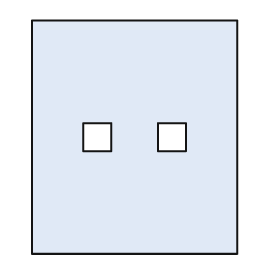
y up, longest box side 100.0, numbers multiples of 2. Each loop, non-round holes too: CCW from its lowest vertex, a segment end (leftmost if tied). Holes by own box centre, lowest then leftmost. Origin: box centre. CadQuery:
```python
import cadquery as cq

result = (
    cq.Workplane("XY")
    .moveTo(-44.0, -50.0)
    .lineTo(44.0, -50.0)
    .lineTo(44.0, 50.0)
    .lineTo(-44.0, 50.0)
    .close()
    .moveTo(-22.0, -6.0)
    .lineTo(-10.0, -6.0)
    .lineTo(-10.0, 6.0)
    .lineTo(-22.0, 6.0)
    .close()
    .moveTo(10.0, -6.0)
    .lineTo(22.0, -6.0)
    .lineTo(22.0, 6.0)
    .lineTo(10.0, 6.0)
    .close()
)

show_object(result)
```